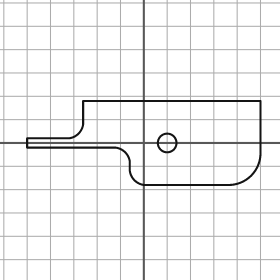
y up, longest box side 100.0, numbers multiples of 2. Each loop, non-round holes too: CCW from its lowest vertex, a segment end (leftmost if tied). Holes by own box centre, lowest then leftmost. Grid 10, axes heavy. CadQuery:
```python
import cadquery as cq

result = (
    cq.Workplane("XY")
    .moveTo(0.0, -18.0)
    .lineTo(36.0, -18.0)
    .threePointArc((46.0, -14.0), (50.0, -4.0))
    .lineTo(50.0, 18.0)
    .lineTo(-26.0, 18.0)
    .lineTo(-26.0, 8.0)
    .threePointArc((-28.0, 4.0), (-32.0, 2.0))
    .lineTo(-50.0, 2.0)
    .lineTo(-50.0, -2.0)
    .lineTo(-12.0, -2.0)
    .threePointArc((-8.0, -4.0), (-6.0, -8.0))
    .lineTo(-6.0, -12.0)
    .threePointArc((-4.0, -16.0), (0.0, -18.0))
    .close()
    .moveTo(10.0, 0.0)
    .circle(4.0)
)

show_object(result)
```